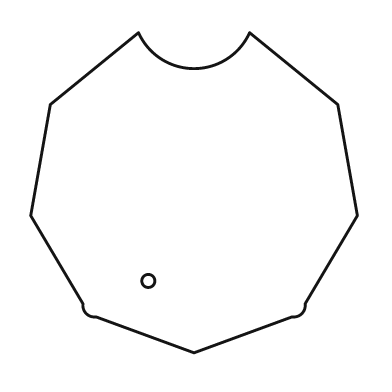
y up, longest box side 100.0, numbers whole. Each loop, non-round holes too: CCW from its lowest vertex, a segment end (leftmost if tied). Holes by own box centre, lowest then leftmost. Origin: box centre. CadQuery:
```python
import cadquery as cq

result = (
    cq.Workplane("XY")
    .moveTo(0.0, -49.0)
    .lineTo(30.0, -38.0)
    .threePointArc((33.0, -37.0), (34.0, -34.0))
    .lineTo(50.0, -7.0)
    .lineTo(44.0, 27.0)
    .lineTo(17.0, 49.0)
    .threePointArc((0.0, 38.0), (-17.0, 49.0))
    .lineTo(-44.0, 27.0)
    .lineTo(-50.0, -7.0)
    .lineTo(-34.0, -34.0)
    .threePointArc((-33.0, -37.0), (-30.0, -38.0))
    .close()
    .moveTo(-14.0, -27.0)
    .circle(2.0)
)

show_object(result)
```